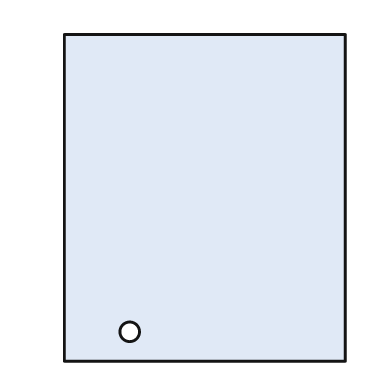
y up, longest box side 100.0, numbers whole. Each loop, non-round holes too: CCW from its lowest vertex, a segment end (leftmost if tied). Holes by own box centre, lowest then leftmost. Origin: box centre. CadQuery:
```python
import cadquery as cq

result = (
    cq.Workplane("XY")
    .moveTo(-43.0, -50.0)
    .lineTo(43.0, -50.0)
    .lineTo(43.0, 50.0)
    .lineTo(-43.0, 50.0)
    .close()
    .moveTo(-23.0, -41.0)
    .circle(3.0)
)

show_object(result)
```